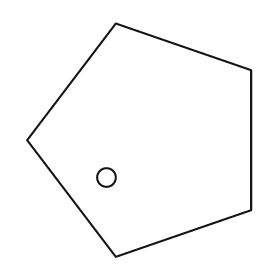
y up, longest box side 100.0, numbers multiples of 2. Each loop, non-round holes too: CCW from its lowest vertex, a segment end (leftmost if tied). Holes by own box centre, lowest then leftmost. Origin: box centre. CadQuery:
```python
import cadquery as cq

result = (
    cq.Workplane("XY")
    .moveTo(-10.0, -50.0)
    .lineTo(48.0, -30.0)
    .lineTo(48.0, 30.0)
    .lineTo(-10.0, 50.0)
    .lineTo(-48.0, 0.0)
    .close()
    .moveTo(-14.0, -16.0)
    .circle(4.0)
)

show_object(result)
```